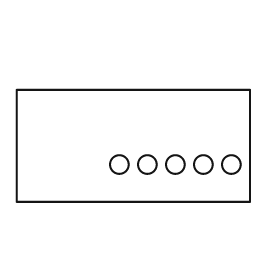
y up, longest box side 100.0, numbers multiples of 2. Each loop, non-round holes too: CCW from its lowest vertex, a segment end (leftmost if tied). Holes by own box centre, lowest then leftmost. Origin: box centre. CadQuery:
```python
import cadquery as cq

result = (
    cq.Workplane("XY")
    .moveTo(-50.0, -24.0)
    .lineTo(50.0, -24.0)
    .lineTo(50.0, 24.0)
    .lineTo(-50.0, 24.0)
    .close()
    .moveTo(-6.0, -8.0)
    .circle(4.0)
    .moveTo(6.0, -8.0)
    .circle(4.0)
    .moveTo(18.0, -8.0)
    .circle(4.0)
    .moveTo(30.0, -8.0)
    .circle(4.0)
    .moveTo(42.0, -8.0)
    .circle(4.0)
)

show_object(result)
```